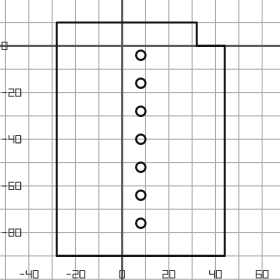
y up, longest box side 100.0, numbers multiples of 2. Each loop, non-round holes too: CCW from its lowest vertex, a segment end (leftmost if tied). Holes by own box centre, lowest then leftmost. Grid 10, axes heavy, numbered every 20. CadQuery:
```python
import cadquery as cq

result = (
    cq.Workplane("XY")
    .moveTo(-28.0, -90.0)
    .lineTo(44.0, -90.0)
    .lineTo(44.0, 0.0)
    .lineTo(32.0, 0.0)
    .lineTo(32.0, 10.0)
    .lineTo(-28.0, 10.0)
    .close()
    .moveTo(8.0, -76.0)
    .circle(2.0)
    .moveTo(8.0, -64.0)
    .circle(2.0)
    .moveTo(8.0, -52.0)
    .circle(2.0)
    .moveTo(8.0, -40.0)
    .circle(2.0)
    .moveTo(8.0, -28.0)
    .circle(2.0)
    .moveTo(8.0, -16.0)
    .circle(2.0)
    .moveTo(8.0, -4.0)
    .circle(2.0)
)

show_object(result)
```